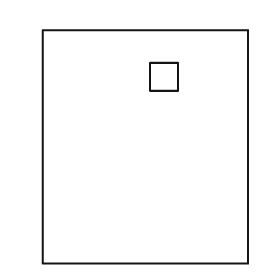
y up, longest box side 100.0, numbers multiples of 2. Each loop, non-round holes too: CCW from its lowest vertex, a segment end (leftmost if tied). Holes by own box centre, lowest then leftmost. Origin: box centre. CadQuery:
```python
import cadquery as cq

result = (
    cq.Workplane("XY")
    .moveTo(-44.0, -50.0)
    .lineTo(44.0, -50.0)
    .lineTo(44.0, 50.0)
    .lineTo(-44.0, 50.0)
    .close()
    .moveTo(2.0, 24.0)
    .lineTo(14.0, 24.0)
    .lineTo(14.0, 36.0)
    .lineTo(2.0, 36.0)
    .close()
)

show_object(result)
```